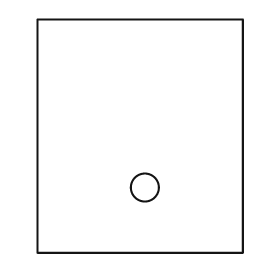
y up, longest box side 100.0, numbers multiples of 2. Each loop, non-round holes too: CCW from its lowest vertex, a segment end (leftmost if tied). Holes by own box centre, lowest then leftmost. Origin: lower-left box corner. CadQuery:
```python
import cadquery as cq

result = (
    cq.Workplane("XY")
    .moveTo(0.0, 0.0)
    .lineTo(88.0, 0.0)
    .lineTo(88.0, 100.0)
    .lineTo(0.0, 100.0)
    .close()
    .moveTo(46.0, 28.0)
    .circle(6.0)
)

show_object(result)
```